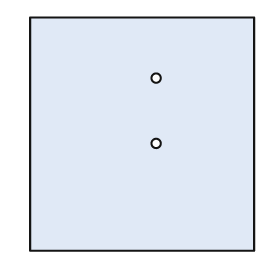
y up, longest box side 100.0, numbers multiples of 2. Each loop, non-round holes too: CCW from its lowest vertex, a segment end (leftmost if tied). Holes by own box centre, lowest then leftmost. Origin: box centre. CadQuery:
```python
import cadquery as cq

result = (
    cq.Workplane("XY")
    .moveTo(-48.0, -50.0)
    .lineTo(48.0, -50.0)
    .lineTo(48.0, 50.0)
    .lineTo(-48.0, 50.0)
    .close()
    .moveTo(6.0, -4.0)
    .circle(2.0)
    .moveTo(6.0, 24.0)
    .circle(2.0)
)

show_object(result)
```